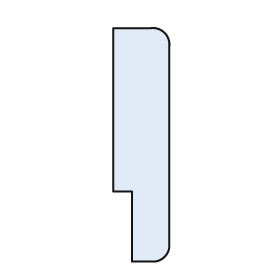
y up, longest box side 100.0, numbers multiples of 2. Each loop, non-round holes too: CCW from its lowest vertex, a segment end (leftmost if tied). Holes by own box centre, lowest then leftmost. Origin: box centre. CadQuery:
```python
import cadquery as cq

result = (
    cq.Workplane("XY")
    .moveTo(-4.0, -50.0)
    .lineTo(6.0, -50.0)
    .threePointArc((10.0, -48.0), (12.0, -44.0))
    .lineTo(12.0, 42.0)
    .threePointArc((10.0, 48.0), (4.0, 50.0))
    .lineTo(-12.0, 50.0)
    .lineTo(-12.0, -20.0)
    .lineTo(-4.0, -20.0)
    .close()
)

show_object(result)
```